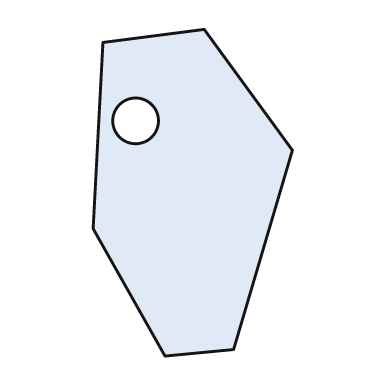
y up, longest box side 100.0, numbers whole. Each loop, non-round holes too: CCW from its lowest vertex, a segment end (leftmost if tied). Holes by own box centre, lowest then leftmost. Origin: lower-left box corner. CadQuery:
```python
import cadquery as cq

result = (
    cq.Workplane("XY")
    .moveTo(22.0, 0.0)
    .lineTo(43.0, 2.0)
    .lineTo(61.0, 63.0)
    .lineTo(34.0, 100.0)
    .lineTo(3.0, 96.0)
    .lineTo(0.0, 39.0)
    .close()
    .moveTo(13.0, 72.0)
    .circle(7.0)
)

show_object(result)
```